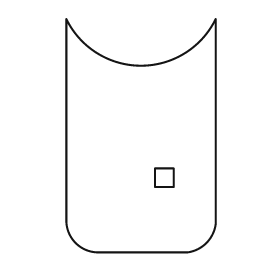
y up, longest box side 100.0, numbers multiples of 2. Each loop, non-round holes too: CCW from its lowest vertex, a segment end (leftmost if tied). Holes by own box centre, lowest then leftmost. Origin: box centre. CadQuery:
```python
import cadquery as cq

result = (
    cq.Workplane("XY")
    .moveTo(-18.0, -50.0)
    .lineTo(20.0, -50.0)
    .threePointArc((28.0, -46.0), (32.0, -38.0))
    .lineTo(32.0, 50.0)
    .threePointArc((0.0, 30.0), (-32.0, 50.0))
    .lineTo(-32.0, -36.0)
    .threePointArc((-28.0, -46.0), (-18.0, -50.0))
    .close()
    .moveTo(6.0, -22.0)
    .lineTo(14.0, -22.0)
    .lineTo(14.0, -14.0)
    .lineTo(6.0, -14.0)
    .close()
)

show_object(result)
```